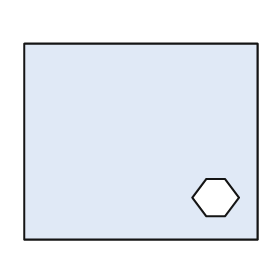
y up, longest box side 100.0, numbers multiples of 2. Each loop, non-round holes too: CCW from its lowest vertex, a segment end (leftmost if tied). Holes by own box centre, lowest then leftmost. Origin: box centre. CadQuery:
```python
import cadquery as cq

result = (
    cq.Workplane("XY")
    .moveTo(-50.0, -42.0)
    .lineTo(50.0, -42.0)
    .lineTo(50.0, 42.0)
    .lineTo(-50.0, 42.0)
    .close()
    .moveTo(28.0, -32.0)
    .lineTo(36.0, -32.0)
    .lineTo(42.0, -24.0)
    .lineTo(36.0, -16.0)
    .lineTo(28.0, -16.0)
    .lineTo(22.0, -24.0)
    .close()
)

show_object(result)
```